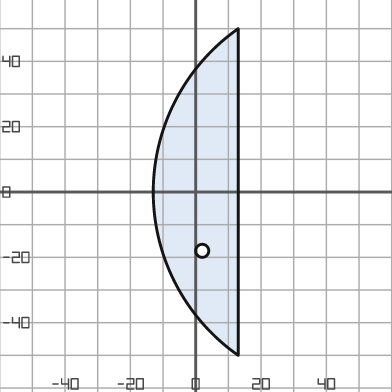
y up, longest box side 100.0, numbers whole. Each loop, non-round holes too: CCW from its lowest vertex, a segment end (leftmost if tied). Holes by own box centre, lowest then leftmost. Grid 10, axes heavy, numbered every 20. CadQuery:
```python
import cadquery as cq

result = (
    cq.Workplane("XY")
    .moveTo(13.0, -50.0)
    .lineTo(13.0, 50.0)
    .threePointArc((-13.0, 0.0), (13.0, -50.0))
    .close()
    .moveTo(2.0, -18.0)
    .circle(2.0)
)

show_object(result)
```